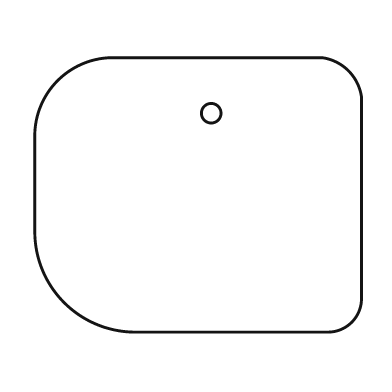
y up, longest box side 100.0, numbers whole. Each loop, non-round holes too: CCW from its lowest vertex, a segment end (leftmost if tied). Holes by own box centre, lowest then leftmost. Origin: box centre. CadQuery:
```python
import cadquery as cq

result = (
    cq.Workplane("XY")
    .moveTo(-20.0, -42.0)
    .lineTo(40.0, -42.0)
    .threePointArc((47.0, -39.0), (50.0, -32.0))
    .lineTo(50.0, 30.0)
    .threePointArc((46.0, 38.0), (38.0, 42.0))
    .lineTo(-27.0, 42.0)
    .threePointArc((-43.0, 35.0), (-50.0, 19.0))
    .lineTo(-50.0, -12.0)
    .threePointArc((-41.0, -33.0), (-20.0, -42.0))
    .close()
    .moveTo(4.0, 25.0)
    .circle(3.0)
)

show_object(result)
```